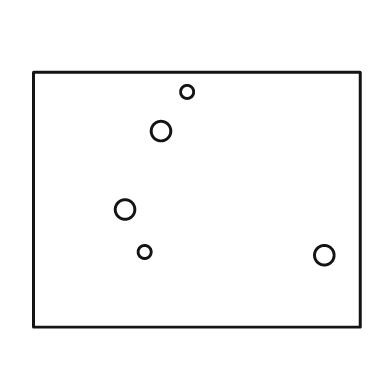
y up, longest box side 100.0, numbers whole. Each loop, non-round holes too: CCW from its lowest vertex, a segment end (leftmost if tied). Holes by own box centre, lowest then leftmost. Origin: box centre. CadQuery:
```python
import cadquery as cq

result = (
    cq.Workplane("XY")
    .moveTo(-50.0, -39.0)
    .lineTo(50.0, -39.0)
    .lineTo(50.0, 39.0)
    .lineTo(-50.0, 39.0)
    .close()
    .moveTo(39.0, -17.0)
    .circle(3.0)
    .moveTo(-16.0, -16.0)
    .circle(2.0)
    .moveTo(-22.0, -3.0)
    .circle(3.0)
    .moveTo(-11.0, 21.0)
    .circle(3.0)
    .moveTo(-3.0, 33.0)
    .circle(2.0)
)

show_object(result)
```